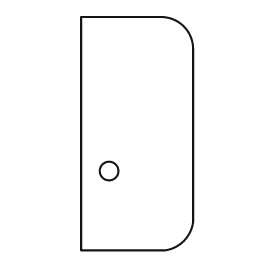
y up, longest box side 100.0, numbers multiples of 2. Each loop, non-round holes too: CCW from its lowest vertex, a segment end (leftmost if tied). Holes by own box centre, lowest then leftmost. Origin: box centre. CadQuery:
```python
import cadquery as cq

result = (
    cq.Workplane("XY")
    .moveTo(-24.0, -50.0)
    .lineTo(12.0, -50.0)
    .threePointArc((20.0, -46.0), (24.0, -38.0))
    .lineTo(24.0, 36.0)
    .threePointArc((20.0, 46.0), (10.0, 50.0))
    .lineTo(-24.0, 50.0)
    .close()
    .moveTo(-12.0, -16.0)
    .circle(4.0)
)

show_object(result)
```